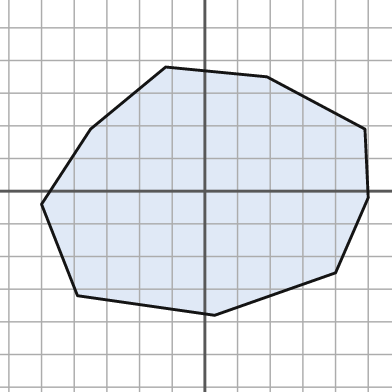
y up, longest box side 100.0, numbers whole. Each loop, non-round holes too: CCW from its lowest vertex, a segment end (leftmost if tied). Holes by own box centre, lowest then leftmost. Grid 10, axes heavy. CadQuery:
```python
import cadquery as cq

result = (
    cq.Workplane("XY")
    .moveTo(3.0, -38.0)
    .lineTo(40.0, -25.0)
    .lineTo(50.0, -2.0)
    .lineTo(49.0, 19.0)
    .lineTo(19.0, 35.0)
    .lineTo(-12.0, 38.0)
    .lineTo(-35.0, 19.0)
    .lineTo(-50.0, -4.0)
    .lineTo(-39.0, -32.0)
    .close()
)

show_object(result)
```